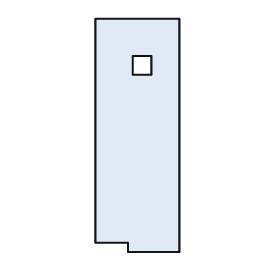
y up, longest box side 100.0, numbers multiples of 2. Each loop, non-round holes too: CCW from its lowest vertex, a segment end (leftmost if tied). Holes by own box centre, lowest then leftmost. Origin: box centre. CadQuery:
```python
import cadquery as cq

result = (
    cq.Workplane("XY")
    .moveTo(-4.0, -50.0)
    .lineTo(18.0, -50.0)
    .lineTo(18.0, 50.0)
    .lineTo(-18.0, 50.0)
    .lineTo(-18.0, -46.0)
    .lineTo(-4.0, -46.0)
    .close()
    .moveTo(-2.0, 26.0)
    .lineTo(6.0, 26.0)
    .lineTo(6.0, 34.0)
    .lineTo(-2.0, 34.0)
    .close()
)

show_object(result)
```